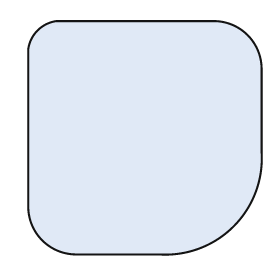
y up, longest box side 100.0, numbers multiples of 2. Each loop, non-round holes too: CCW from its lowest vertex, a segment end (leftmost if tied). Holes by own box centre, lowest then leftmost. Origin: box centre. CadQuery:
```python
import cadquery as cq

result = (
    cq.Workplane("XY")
    .moveTo(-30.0, -50.0)
    .lineTo(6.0, -50.0)
    .threePointArc((38.0, -38.0), (50.0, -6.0))
    .lineTo(50.0, 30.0)
    .threePointArc((44.0, 44.0), (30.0, 50.0))
    .lineTo(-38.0, 50.0)
    .threePointArc((-46.0, 46.0), (-50.0, 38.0))
    .lineTo(-50.0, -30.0)
    .threePointArc((-44.0, -44.0), (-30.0, -50.0))
    .close()
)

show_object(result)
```